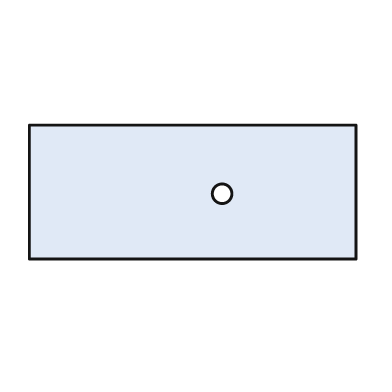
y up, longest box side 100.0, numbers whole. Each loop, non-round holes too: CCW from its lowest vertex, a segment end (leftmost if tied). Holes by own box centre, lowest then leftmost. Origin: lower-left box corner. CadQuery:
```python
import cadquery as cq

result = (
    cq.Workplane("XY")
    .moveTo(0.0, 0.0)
    .lineTo(100.0, 0.0)
    .lineTo(100.0, 41.0)
    .lineTo(0.0, 41.0)
    .close()
    .moveTo(59.0, 20.0)
    .circle(3.0)
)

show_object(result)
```